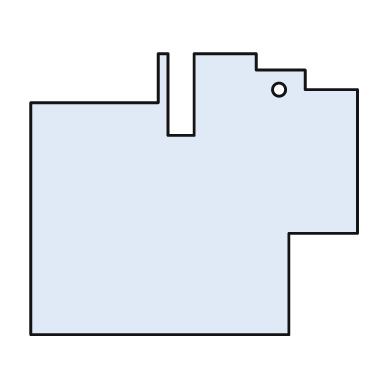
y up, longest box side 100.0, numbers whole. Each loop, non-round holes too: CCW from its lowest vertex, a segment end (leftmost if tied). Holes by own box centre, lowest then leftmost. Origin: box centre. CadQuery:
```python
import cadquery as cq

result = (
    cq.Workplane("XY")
    .moveTo(-50.0, -43.0)
    .lineTo(29.0, -43.0)
    .lineTo(29.0, -12.0)
    .lineTo(50.0, -12.0)
    .lineTo(50.0, 32.0)
    .lineTo(34.0, 32.0)
    .lineTo(34.0, 38.0)
    .lineTo(19.0, 38.0)
    .lineTo(19.0, 43.0)
    .lineTo(0.0, 43.0)
    .lineTo(0.0, 18.0)
    .lineTo(-8.0, 18.0)
    .lineTo(-8.0, 43.0)
    .lineTo(-11.0, 43.0)
    .lineTo(-11.0, 28.0)
    .lineTo(-50.0, 28.0)
    .close()
    .moveTo(26.0, 32.0)
    .circle(2.0)
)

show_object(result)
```